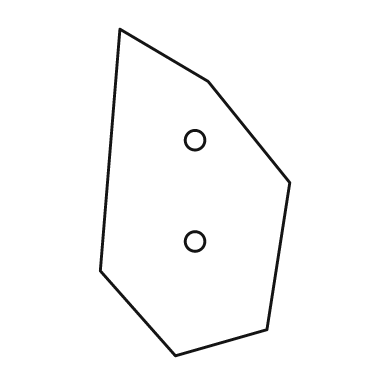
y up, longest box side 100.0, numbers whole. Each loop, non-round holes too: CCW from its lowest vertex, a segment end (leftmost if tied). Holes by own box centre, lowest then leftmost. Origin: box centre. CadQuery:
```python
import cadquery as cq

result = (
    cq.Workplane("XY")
    .moveTo(-6.0, -50.0)
    .lineTo(22.0, -42.0)
    .lineTo(29.0, 3.0)
    .lineTo(4.0, 34.0)
    .lineTo(-23.0, 50.0)
    .lineTo(-29.0, -24.0)
    .close()
    .moveTo(0.0, -15.0)
    .circle(3.0)
    .moveTo(0.0, 16.0)
    .circle(3.0)
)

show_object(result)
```